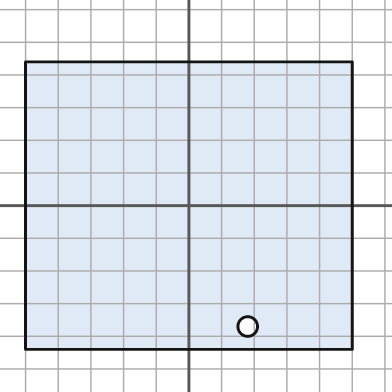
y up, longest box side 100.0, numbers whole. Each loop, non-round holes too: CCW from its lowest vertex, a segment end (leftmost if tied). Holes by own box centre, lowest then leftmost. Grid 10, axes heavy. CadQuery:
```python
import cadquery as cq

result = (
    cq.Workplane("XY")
    .moveTo(-50.0, -44.0)
    .lineTo(50.0, -44.0)
    .lineTo(50.0, 44.0)
    .lineTo(-50.0, 44.0)
    .close()
    .moveTo(18.0, -37.0)
    .circle(3.0)
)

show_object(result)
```